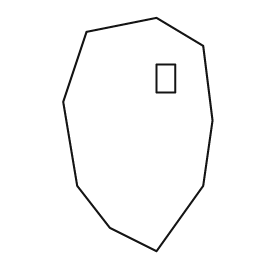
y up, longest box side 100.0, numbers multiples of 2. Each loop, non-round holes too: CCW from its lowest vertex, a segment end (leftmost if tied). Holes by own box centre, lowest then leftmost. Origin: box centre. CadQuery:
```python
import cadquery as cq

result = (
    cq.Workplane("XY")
    .moveTo(8.0, -50.0)
    .lineTo(28.0, -22.0)
    .lineTo(32.0, 6.0)
    .lineTo(28.0, 38.0)
    .lineTo(8.0, 50.0)
    .lineTo(-22.0, 44.0)
    .lineTo(-32.0, 14.0)
    .lineTo(-26.0, -22.0)
    .lineTo(-12.0, -40.0)
    .close()
    .moveTo(8.0, 18.0)
    .lineTo(16.0, 18.0)
    .lineTo(16.0, 30.0)
    .lineTo(8.0, 30.0)
    .close()
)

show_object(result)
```